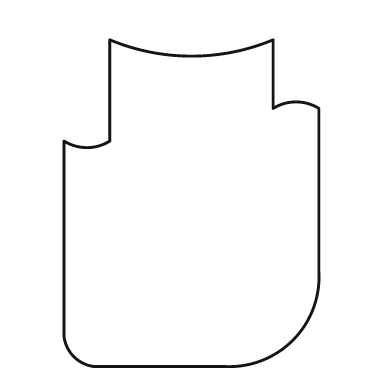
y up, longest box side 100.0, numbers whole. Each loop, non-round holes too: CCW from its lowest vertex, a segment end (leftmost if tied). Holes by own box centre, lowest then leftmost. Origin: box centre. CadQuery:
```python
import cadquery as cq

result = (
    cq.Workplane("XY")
    .moveTo(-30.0, -50.0)
    .lineTo(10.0, -50.0)
    .threePointArc((31.0, -42.0), (39.0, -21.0))
    .lineTo(39.0, 29.0)
    .threePointArc((32.0, 31.0), (25.0, 29.0))
    .lineTo(25.0, 50.0)
    .threePointArc((0.0, 45.0), (-25.0, 50.0))
    .lineTo(-25.0, 19.0)
    .threePointArc((-32.0, 17.0), (-39.0, 19.0))
    .lineTo(-39.0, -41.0)
    .threePointArc((-36.0, -47.0), (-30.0, -50.0))
    .close()
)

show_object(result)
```